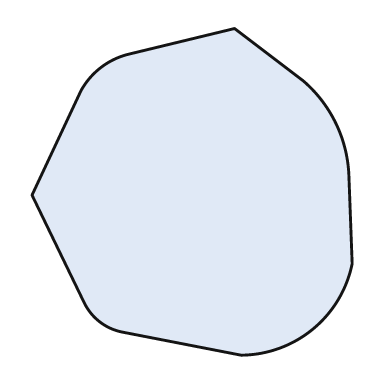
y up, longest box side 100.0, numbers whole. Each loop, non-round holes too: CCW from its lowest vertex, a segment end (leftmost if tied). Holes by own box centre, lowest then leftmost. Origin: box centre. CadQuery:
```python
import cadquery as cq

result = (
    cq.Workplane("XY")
    .moveTo(15.0, -50.0)
    .threePointArc((37.0, -42.0), (49.0, -22.0))
    .lineTo(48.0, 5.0)
    .threePointArc((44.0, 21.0), (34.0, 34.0))
    .lineTo(13.0, 50.0)
    .lineTo(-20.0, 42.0)
    .threePointArc((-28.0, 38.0), (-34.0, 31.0))
    .lineTo(-49.0, -1.0)
    .lineTo(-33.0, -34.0)
    .threePointArc((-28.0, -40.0), (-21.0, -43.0))
    .close()
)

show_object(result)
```